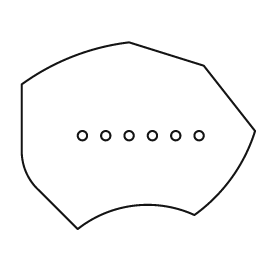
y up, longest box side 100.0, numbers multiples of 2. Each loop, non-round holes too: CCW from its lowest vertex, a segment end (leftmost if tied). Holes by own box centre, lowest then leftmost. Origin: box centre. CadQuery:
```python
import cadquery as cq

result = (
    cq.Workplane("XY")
    .moveTo(-26.0, -40.0)
    .threePointArc((-2.0, -30.0), (24.0, -34.0))
    .threePointArc((40.0, -18.0), (50.0, 2.0))
    .lineTo(28.0, 30.0)
    .lineTo(-4.0, 40.0)
    .threePointArc((-28.0, 34.0), (-50.0, 22.0))
    .lineTo(-50.0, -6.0)
    .threePointArc((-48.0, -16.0), (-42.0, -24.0))
    .close()
    .moveTo(-24.0, 0.0)
    .circle(2.0)
    .moveTo(-14.0, 0.0)
    .circle(2.0)
    .moveTo(-4.0, 0.0)
    .circle(2.0)
    .moveTo(6.0, 0.0)
    .circle(2.0)
    .moveTo(16.0, 0.0)
    .circle(2.0)
    .moveTo(26.0, 0.0)
    .circle(2.0)
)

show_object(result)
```